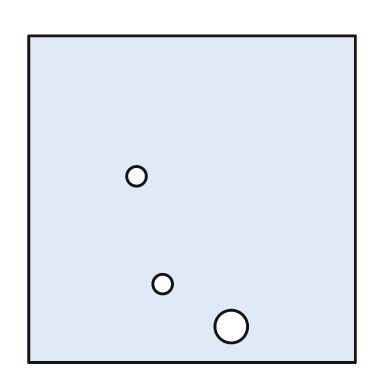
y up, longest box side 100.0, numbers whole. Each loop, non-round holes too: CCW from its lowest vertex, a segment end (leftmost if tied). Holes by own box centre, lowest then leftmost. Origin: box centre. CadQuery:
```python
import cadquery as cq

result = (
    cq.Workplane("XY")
    .moveTo(-50.0, -50.0)
    .lineTo(50.0, -50.0)
    .lineTo(50.0, 50.0)
    .lineTo(-50.0, 50.0)
    .close()
    .moveTo(12.0, -39.0)
    .circle(5.0)
    .moveTo(-9.0, -26.0)
    .circle(3.0)
    .moveTo(-17.0, 7.0)
    .circle(3.0)
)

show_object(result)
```